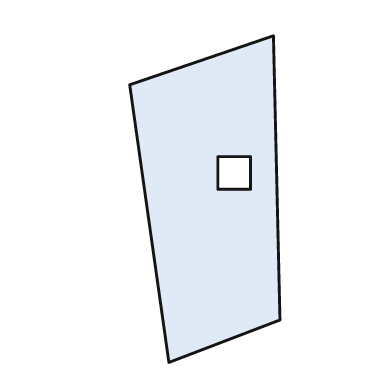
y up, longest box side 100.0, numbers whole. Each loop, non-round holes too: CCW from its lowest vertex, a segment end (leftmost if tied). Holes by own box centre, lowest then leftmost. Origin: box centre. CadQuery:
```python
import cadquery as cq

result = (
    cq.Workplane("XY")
    .moveTo(-11.0, -50.0)
    .lineTo(23.0, -37.0)
    .lineTo(21.0, 50.0)
    .lineTo(-23.0, 35.0)
    .close()
    .moveTo(4.0, 3.0)
    .lineTo(14.0, 3.0)
    .lineTo(14.0, 13.0)
    .lineTo(4.0, 13.0)
    .close()
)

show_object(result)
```